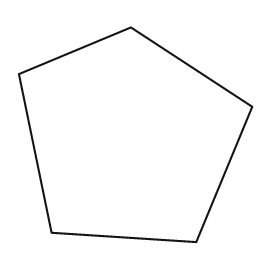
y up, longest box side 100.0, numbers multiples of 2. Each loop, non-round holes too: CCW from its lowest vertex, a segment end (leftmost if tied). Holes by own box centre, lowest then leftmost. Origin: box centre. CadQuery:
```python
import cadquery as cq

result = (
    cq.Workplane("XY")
    .moveTo(26.0, -46.0)
    .lineTo(50.0, 12.0)
    .lineTo(-2.0, 46.0)
    .lineTo(-50.0, 26.0)
    .lineTo(-36.0, -42.0)
    .close()
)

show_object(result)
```